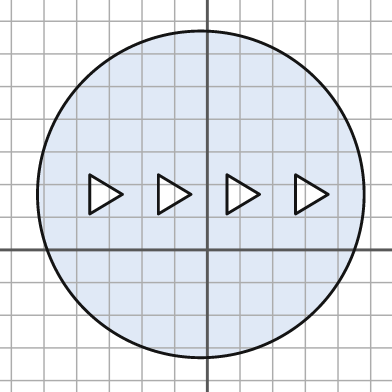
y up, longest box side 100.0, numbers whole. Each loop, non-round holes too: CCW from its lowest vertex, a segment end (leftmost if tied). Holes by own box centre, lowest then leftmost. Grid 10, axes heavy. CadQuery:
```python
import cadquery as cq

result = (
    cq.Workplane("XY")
    .moveTo(-2.0, 17.0)
    .circle(50.0)
    .moveTo(-36.0, 11.0)
    .lineTo(-26.0, 17.0)
    .lineTo(-36.0, 23.0)
    .close()
    .moveTo(-15.0, 11.0)
    .lineTo(-5.0, 17.0)
    .lineTo(-15.0, 23.0)
    .close()
    .moveTo(6.0, 11.0)
    .lineTo(16.0, 17.0)
    .lineTo(6.0, 23.0)
    .close()
    .moveTo(27.0, 11.0)
    .lineTo(37.0, 17.0)
    .lineTo(27.0, 23.0)
    .close()
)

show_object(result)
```